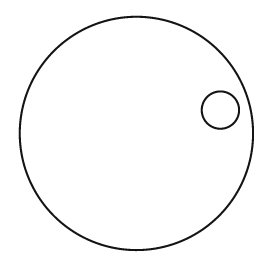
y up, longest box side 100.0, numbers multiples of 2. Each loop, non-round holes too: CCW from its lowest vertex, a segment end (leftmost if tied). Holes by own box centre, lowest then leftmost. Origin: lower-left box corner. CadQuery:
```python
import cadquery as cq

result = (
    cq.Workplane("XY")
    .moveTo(50.0, 50.0)
    .circle(50.0)
    .moveTo(86.0, 60.0)
    .circle(8.0)
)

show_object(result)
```